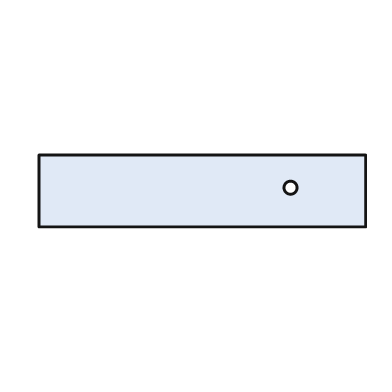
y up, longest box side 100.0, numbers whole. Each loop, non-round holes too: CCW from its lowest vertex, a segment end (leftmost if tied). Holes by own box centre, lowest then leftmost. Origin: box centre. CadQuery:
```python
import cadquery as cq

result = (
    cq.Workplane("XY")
    .moveTo(-50.0, -11.0)
    .lineTo(50.0, -11.0)
    .lineTo(50.0, 11.0)
    .lineTo(-50.0, 11.0)
    .close()
    .moveTo(27.0, 1.0)
    .circle(2.0)
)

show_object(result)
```